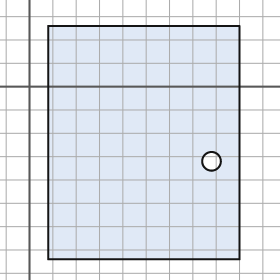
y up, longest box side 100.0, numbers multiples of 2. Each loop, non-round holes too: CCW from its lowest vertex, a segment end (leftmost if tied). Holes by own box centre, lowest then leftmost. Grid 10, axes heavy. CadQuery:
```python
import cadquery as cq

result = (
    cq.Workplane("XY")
    .moveTo(8.0, -74.0)
    .lineTo(90.0, -74.0)
    .lineTo(90.0, 26.0)
    .lineTo(8.0, 26.0)
    .close()
    .moveTo(78.0, -32.0)
    .circle(4.0)
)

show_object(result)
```